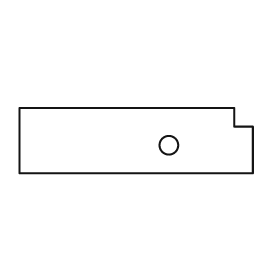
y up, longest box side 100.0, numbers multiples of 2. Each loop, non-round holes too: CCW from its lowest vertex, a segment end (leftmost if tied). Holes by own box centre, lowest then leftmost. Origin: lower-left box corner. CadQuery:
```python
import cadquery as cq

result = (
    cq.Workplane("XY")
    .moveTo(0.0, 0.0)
    .lineTo(100.0, 0.0)
    .lineTo(100.0, 20.0)
    .lineTo(92.0, 20.0)
    .lineTo(92.0, 28.0)
    .lineTo(0.0, 28.0)
    .close()
    .moveTo(64.0, 12.0)
    .circle(4.0)
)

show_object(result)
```